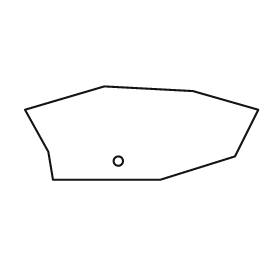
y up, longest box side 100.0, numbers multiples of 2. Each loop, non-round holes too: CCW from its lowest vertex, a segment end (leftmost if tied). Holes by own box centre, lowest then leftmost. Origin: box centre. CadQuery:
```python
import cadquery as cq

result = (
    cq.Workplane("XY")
    .moveTo(-38.0, -20.0)
    .lineTo(8.0, -20.0)
    .lineTo(40.0, -10.0)
    .lineTo(50.0, 10.0)
    .lineTo(22.0, 18.0)
    .lineTo(-16.0, 20.0)
    .lineTo(-50.0, 10.0)
    .lineTo(-40.0, -8.0)
    .close()
    .moveTo(-10.0, -12.0)
    .circle(2.0)
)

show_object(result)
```